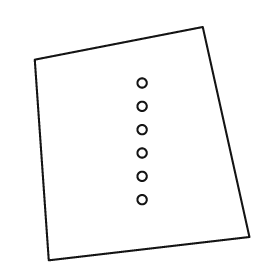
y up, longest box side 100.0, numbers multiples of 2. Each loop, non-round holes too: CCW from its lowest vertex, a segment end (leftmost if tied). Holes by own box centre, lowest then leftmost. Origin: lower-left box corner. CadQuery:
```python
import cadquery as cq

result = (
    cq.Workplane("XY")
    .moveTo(6.0, 0.0)
    .lineTo(92.0, 10.0)
    .lineTo(72.0, 100.0)
    .lineTo(0.0, 86.0)
    .close()
    .moveTo(46.0, 26.0)
    .circle(2.0)
    .moveTo(46.0, 36.0)
    .circle(2.0)
    .moveTo(46.0, 46.0)
    .circle(2.0)
    .moveTo(46.0, 56.0)
    .circle(2.0)
    .moveTo(46.0, 66.0)
    .circle(2.0)
    .moveTo(46.0, 76.0)
    .circle(2.0)
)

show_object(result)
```